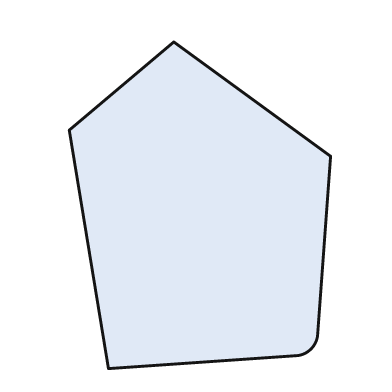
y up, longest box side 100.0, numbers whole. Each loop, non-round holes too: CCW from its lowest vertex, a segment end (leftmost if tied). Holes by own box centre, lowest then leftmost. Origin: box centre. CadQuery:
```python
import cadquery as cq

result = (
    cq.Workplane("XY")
    .moveTo(-28.0, -50.0)
    .lineTo(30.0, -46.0)
    .threePointArc((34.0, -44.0), (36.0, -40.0))
    .lineTo(40.0, 15.0)
    .lineTo(-8.0, 50.0)
    .lineTo(-40.0, 23.0)
    .close()
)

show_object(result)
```